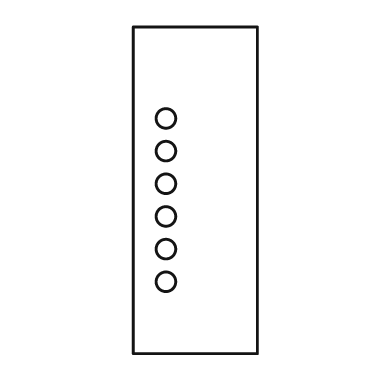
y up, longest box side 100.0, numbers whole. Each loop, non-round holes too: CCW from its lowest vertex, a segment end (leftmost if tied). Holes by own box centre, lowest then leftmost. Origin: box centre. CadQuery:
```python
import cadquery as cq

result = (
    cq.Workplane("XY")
    .moveTo(-19.0, -50.0)
    .lineTo(19.0, -50.0)
    .lineTo(19.0, 50.0)
    .lineTo(-19.0, 50.0)
    .close()
    .moveTo(-9.0, -28.0)
    .circle(3.0)
    .moveTo(-9.0, -18.0)
    .circle(3.0)
    .moveTo(-9.0, -8.0)
    .circle(3.0)
    .moveTo(-9.0, 2.0)
    .circle(3.0)
    .moveTo(-9.0, 12.0)
    .circle(3.0)
    .moveTo(-9.0, 22.0)
    .circle(3.0)
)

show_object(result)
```